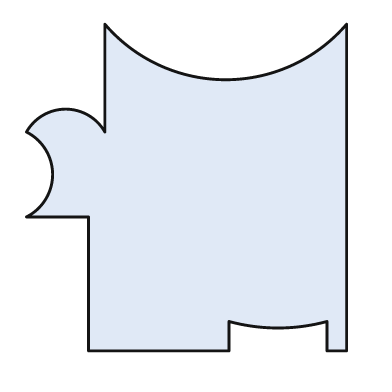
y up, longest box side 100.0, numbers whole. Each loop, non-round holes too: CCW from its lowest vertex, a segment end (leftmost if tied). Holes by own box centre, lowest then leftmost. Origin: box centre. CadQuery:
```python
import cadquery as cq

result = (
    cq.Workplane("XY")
    .moveTo(-30.0, -50.0)
    .lineTo(13.0, -50.0)
    .lineTo(13.0, -41.0)
    .threePointArc((28.0, -43.0), (43.0, -41.0))
    .lineTo(43.0, -50.0)
    .lineTo(49.0, -50.0)
    .lineTo(49.0, 50.0)
    .threePointArc((12.0, 33.0), (-25.0, 50.0))
    .lineTo(-25.0, 17.0)
    .threePointArc((-37.0, 24.0), (-49.0, 17.0))
    .threePointArc((-41.0, 4.0), (-49.0, -9.0))
    .lineTo(-30.0, -9.0)
    .close()
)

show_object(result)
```